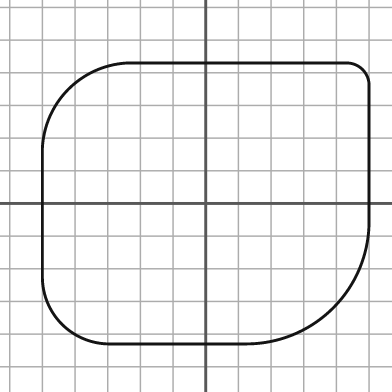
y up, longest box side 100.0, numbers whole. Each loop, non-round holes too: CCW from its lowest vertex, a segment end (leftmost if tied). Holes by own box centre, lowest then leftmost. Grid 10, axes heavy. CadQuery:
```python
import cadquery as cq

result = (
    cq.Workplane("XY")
    .moveTo(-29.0, -43.0)
    .lineTo(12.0, -43.0)
    .threePointArc((39.0, -32.0), (50.0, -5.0))
    .lineTo(50.0, 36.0)
    .threePointArc((48.0, 41.0), (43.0, 43.0))
    .lineTo(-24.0, 43.0)
    .threePointArc((-42.0, 35.0), (-50.0, 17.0))
    .lineTo(-50.0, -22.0)
    .threePointArc((-44.0, -37.0), (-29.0, -43.0))
    .close()
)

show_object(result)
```